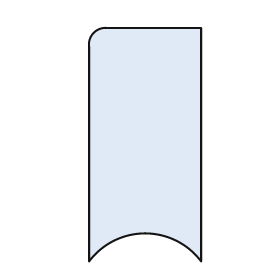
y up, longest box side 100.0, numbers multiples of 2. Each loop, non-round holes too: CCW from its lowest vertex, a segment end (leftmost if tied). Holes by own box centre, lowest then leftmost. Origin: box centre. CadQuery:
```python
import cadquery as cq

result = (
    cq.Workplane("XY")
    .moveTo(-24.0, -50.0)
    .threePointArc((0.0, -38.0), (24.0, -50.0))
    .lineTo(24.0, 50.0)
    .lineTo(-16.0, 50.0)
    .threePointArc((-22.0, 48.0), (-24.0, 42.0))
    .close()
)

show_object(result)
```